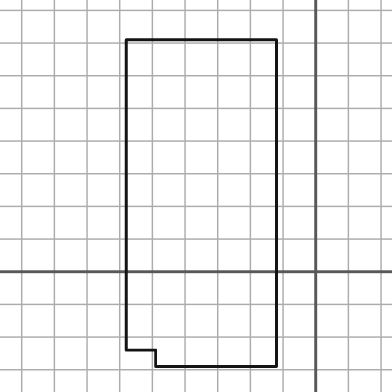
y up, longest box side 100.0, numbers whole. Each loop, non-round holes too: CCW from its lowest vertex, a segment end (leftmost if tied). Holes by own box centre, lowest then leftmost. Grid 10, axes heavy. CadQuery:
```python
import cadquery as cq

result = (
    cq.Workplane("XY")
    .moveTo(-49.0, -29.0)
    .lineTo(-12.0, -29.0)
    .lineTo(-12.0, 71.0)
    .lineTo(-58.0, 71.0)
    .lineTo(-58.0, -24.0)
    .lineTo(-49.0, -24.0)
    .close()
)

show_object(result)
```